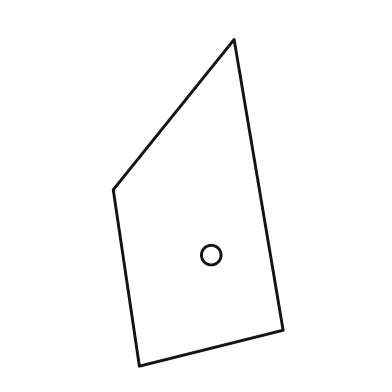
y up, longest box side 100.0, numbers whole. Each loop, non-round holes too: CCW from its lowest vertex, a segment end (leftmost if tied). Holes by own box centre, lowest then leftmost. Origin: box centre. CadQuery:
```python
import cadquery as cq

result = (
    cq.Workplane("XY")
    .moveTo(-18.0, -50.0)
    .lineTo(26.0, -39.0)
    .lineTo(11.0, 50.0)
    .lineTo(-26.0, 4.0)
    .close()
    .moveTo(4.0, -16.0)
    .circle(3.0)
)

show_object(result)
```